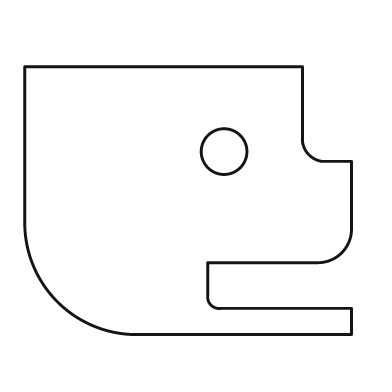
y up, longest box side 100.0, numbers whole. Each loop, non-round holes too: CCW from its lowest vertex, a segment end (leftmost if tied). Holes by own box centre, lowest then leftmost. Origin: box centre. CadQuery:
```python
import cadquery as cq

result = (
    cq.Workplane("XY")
    .moveTo(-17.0, -41.0)
    .lineTo(50.0, -41.0)
    .lineTo(50.0, -33.0)
    .lineTo(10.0, -33.0)
    .threePointArc((7.0, -32.0), (6.0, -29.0))
    .lineTo(6.0, -19.0)
    .lineTo(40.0, -19.0)
    .threePointArc((47.0, -16.0), (50.0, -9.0))
    .lineTo(50.0, 12.0)
    .lineTo(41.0, 12.0)
    .threePointArc((37.0, 14.0), (35.0, 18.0))
    .lineTo(35.0, 41.0)
    .lineTo(-50.0, 41.0)
    .lineTo(-50.0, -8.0)
    .threePointArc((-40.0, -31.0), (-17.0, -41.0))
    .close()
    .moveTo(11.0, 15.0)
    .circle(7.0)
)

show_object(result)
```